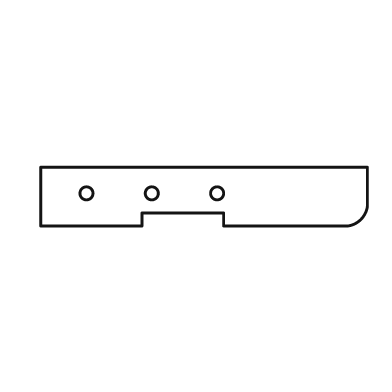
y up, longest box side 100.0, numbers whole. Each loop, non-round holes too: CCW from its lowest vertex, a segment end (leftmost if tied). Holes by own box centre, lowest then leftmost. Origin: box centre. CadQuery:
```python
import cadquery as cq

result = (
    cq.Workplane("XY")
    .moveTo(-50.0, -9.0)
    .lineTo(-19.0, -9.0)
    .lineTo(-19.0, -5.0)
    .lineTo(6.0, -5.0)
    .lineTo(6.0, -9.0)
    .lineTo(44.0, -9.0)
    .threePointArc((48.0, -7.0), (50.0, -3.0))
    .lineTo(50.0, 9.0)
    .lineTo(-50.0, 9.0)
    .close()
    .moveTo(-36.0, 1.0)
    .circle(2.0)
    .moveTo(-16.0, 1.0)
    .circle(2.0)
    .moveTo(4.0, 1.0)
    .circle(2.0)
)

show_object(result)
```